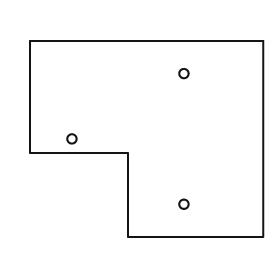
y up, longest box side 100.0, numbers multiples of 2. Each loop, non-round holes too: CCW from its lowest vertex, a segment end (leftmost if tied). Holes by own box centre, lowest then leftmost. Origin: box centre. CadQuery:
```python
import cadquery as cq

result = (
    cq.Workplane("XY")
    .moveTo(-8.0, -42.0)
    .lineTo(50.0, -42.0)
    .lineTo(50.0, 42.0)
    .lineTo(-50.0, 42.0)
    .lineTo(-50.0, -6.0)
    .lineTo(-8.0, -6.0)
    .close()
    .moveTo(16.0, -28.0)
    .circle(2.0)
    .moveTo(-32.0, 0.0)
    .circle(2.0)
    .moveTo(16.0, 28.0)
    .circle(2.0)
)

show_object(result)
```